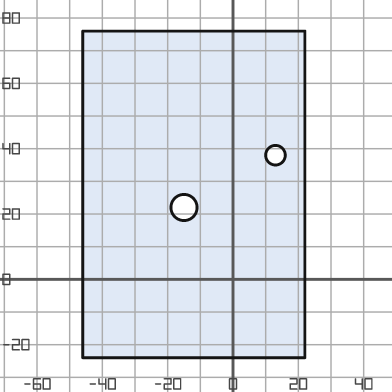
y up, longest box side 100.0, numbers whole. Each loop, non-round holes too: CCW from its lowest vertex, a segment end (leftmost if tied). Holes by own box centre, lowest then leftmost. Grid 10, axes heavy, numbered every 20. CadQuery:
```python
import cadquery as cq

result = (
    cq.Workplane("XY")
    .moveTo(-46.0, -24.0)
    .lineTo(22.0, -24.0)
    .lineTo(22.0, 76.0)
    .lineTo(-46.0, 76.0)
    .close()
    .moveTo(-15.0, 22.0)
    .circle(4.0)
    .moveTo(13.0, 38.0)
    .circle(3.0)
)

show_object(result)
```